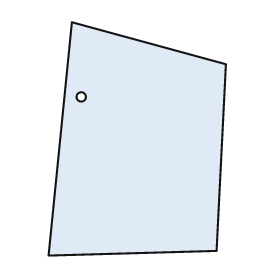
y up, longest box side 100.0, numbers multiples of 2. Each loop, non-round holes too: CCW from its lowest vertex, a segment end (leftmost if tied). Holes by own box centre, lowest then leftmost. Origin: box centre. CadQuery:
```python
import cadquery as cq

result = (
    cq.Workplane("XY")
    .moveTo(-38.0, -50.0)
    .lineTo(34.0, -48.0)
    .lineTo(38.0, 32.0)
    .lineTo(-28.0, 50.0)
    .close()
    .moveTo(-24.0, 18.0)
    .circle(2.0)
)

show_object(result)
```